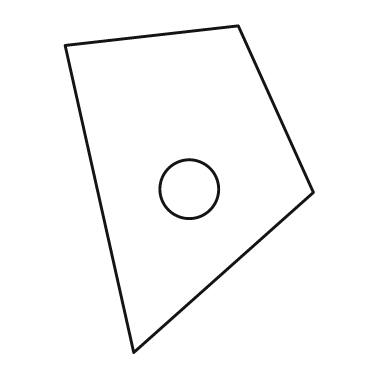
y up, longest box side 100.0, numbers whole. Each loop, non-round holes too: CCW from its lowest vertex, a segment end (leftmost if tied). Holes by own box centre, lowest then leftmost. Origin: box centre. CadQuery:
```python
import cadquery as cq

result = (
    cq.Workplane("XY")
    .moveTo(-17.0, -50.0)
    .lineTo(38.0, -1.0)
    .lineTo(15.0, 50.0)
    .lineTo(-38.0, 44.0)
    .close()
    .moveTo(0.0, 0.0)
    .circle(9.0)
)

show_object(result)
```